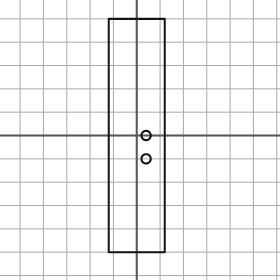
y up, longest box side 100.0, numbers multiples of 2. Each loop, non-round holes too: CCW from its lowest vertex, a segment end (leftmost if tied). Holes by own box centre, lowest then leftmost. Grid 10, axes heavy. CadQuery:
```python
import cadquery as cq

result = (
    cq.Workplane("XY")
    .moveTo(-12.0, -50.0)
    .lineTo(12.0, -50.0)
    .lineTo(12.0, 50.0)
    .lineTo(-12.0, 50.0)
    .close()
    .moveTo(4.0, -10.0)
    .circle(2.0)
    .moveTo(4.0, 0.0)
    .circle(2.0)
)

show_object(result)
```